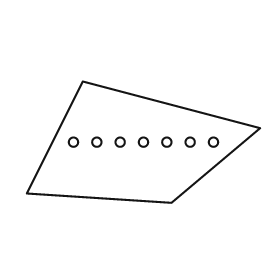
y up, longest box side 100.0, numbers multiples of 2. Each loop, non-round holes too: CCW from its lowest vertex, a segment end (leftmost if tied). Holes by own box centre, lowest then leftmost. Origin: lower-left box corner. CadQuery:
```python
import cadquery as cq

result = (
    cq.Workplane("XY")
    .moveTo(62.0, 0.0)
    .lineTo(100.0, 32.0)
    .lineTo(24.0, 52.0)
    .lineTo(0.0, 4.0)
    .close()
    .moveTo(20.0, 26.0)
    .circle(2.0)
    .moveTo(30.0, 26.0)
    .circle(2.0)
    .moveTo(40.0, 26.0)
    .circle(2.0)
    .moveTo(50.0, 26.0)
    .circle(2.0)
    .moveTo(60.0, 26.0)
    .circle(2.0)
    .moveTo(70.0, 26.0)
    .circle(2.0)
    .moveTo(80.0, 26.0)
    .circle(2.0)
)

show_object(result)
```